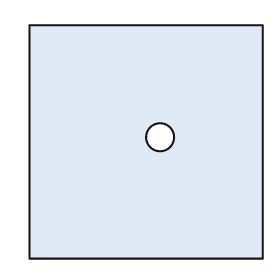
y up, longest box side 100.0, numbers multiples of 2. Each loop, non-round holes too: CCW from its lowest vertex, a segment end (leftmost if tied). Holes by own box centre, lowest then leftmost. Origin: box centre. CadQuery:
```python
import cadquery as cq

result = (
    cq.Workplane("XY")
    .moveTo(-50.0, -50.0)
    .lineTo(50.0, -50.0)
    .lineTo(50.0, 50.0)
    .lineTo(-50.0, 50.0)
    .close()
    .moveTo(6.0, 2.0)
    .circle(6.0)
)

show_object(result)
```